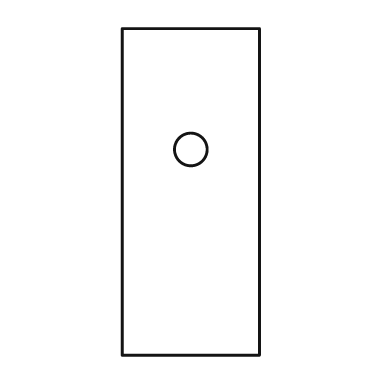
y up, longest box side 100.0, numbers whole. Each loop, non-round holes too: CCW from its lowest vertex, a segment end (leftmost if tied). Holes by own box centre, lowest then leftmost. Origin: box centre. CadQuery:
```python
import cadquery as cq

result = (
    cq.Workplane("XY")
    .moveTo(-21.0, -50.0)
    .lineTo(21.0, -50.0)
    .lineTo(21.0, 50.0)
    .lineTo(-21.0, 50.0)
    .close()
    .moveTo(0.0, 13.0)
    .circle(5.0)
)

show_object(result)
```